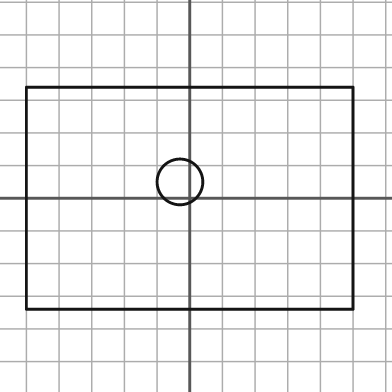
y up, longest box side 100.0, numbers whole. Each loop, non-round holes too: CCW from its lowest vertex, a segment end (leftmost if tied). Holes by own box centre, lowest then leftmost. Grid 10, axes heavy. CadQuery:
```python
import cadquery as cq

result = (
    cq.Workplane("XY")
    .moveTo(-50.0, -34.0)
    .lineTo(50.0, -34.0)
    .lineTo(50.0, 34.0)
    .lineTo(-50.0, 34.0)
    .close()
    .moveTo(-3.0, 5.0)
    .circle(7.0)
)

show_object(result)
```